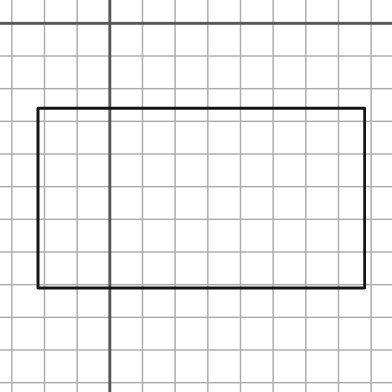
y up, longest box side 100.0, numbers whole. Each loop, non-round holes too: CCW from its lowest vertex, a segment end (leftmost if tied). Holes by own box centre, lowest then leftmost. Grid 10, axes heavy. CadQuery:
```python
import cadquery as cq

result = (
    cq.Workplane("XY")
    .moveTo(-22.0, -81.0)
    .lineTo(78.0, -81.0)
    .lineTo(78.0, -26.0)
    .lineTo(-22.0, -26.0)
    .close()
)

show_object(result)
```